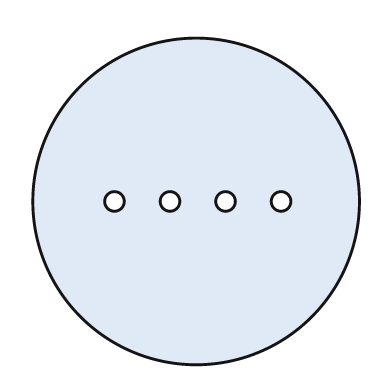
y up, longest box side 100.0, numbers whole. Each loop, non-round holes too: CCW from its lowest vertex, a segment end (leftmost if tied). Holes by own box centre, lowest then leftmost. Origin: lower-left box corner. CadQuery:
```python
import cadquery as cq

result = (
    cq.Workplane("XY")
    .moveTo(50.0, 50.0)
    .circle(50.0)
    .moveTo(25.0, 50.0)
    .circle(3.0)
    .moveTo(42.0, 50.0)
    .circle(3.0)
    .moveTo(59.0, 50.0)
    .circle(3.0)
    .moveTo(76.0, 50.0)
    .circle(3.0)
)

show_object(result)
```